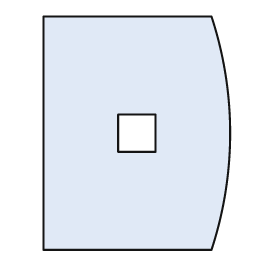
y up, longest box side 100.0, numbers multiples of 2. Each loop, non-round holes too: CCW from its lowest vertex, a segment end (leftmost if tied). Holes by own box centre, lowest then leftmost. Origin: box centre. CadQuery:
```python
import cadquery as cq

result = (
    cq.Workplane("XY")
    .moveTo(-40.0, -50.0)
    .lineTo(32.0, -50.0)
    .threePointArc((40.0, 0.0), (32.0, 50.0))
    .lineTo(-40.0, 50.0)
    .close()
    .moveTo(-8.0, -8.0)
    .lineTo(8.0, -8.0)
    .lineTo(8.0, 8.0)
    .lineTo(-8.0, 8.0)
    .close()
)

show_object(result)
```